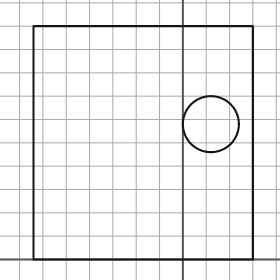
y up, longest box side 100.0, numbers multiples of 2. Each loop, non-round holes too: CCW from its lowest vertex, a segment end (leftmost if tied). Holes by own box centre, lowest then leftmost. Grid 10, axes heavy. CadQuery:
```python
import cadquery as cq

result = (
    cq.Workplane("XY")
    .moveTo(-64.0, 0.0)
    .lineTo(30.0, 0.0)
    .lineTo(30.0, 100.0)
    .lineTo(-64.0, 100.0)
    .close()
    .moveTo(12.0, 58.0)
    .circle(12.0)
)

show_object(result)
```